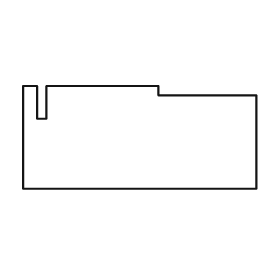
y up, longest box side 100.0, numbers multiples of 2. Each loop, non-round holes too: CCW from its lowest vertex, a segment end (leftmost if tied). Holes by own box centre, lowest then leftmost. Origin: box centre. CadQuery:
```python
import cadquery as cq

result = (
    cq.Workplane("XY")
    .moveTo(-50.0, -22.0)
    .lineTo(50.0, -22.0)
    .lineTo(50.0, 18.0)
    .lineTo(8.0, 18.0)
    .lineTo(8.0, 22.0)
    .lineTo(-40.0, 22.0)
    .lineTo(-40.0, 8.0)
    .lineTo(-44.0, 8.0)
    .lineTo(-44.0, 22.0)
    .lineTo(-50.0, 22.0)
    .close()
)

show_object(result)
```